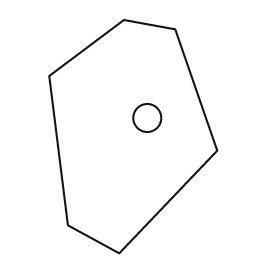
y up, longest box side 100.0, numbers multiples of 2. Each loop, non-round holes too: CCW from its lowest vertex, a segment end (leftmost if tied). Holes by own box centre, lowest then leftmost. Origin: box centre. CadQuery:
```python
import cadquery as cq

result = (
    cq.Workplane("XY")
    .moveTo(-6.0, -50.0)
    .lineTo(36.0, -6.0)
    .lineTo(18.0, 46.0)
    .lineTo(-4.0, 50.0)
    .lineTo(-36.0, 26.0)
    .lineTo(-28.0, -38.0)
    .close()
    .moveTo(6.0, 8.0)
    .circle(6.0)
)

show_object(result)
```